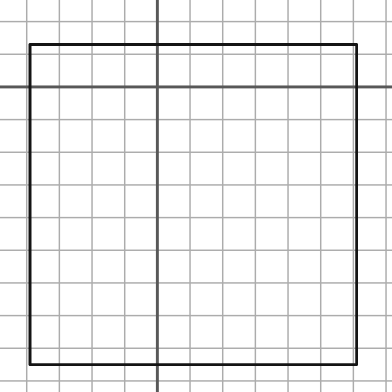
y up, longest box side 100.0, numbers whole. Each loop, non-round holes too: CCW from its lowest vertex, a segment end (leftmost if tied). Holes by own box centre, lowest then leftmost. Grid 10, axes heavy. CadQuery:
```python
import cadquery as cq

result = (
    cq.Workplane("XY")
    .moveTo(-39.0, -85.0)
    .lineTo(61.0, -85.0)
    .lineTo(61.0, 13.0)
    .lineTo(-39.0, 13.0)
    .close()
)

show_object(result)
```